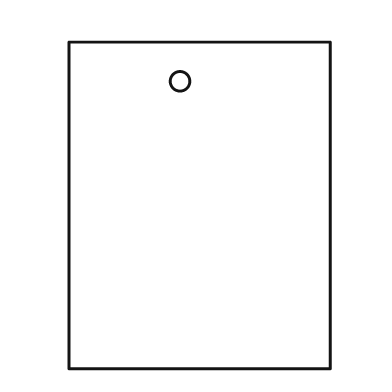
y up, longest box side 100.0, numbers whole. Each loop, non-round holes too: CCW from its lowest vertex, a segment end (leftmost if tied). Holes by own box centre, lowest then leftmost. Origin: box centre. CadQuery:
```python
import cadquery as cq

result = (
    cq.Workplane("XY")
    .moveTo(-40.0, -50.0)
    .lineTo(40.0, -50.0)
    .lineTo(40.0, 50.0)
    .lineTo(-40.0, 50.0)
    .close()
    .moveTo(-6.0, 38.0)
    .circle(3.0)
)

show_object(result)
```